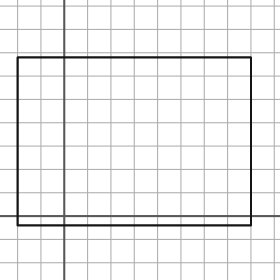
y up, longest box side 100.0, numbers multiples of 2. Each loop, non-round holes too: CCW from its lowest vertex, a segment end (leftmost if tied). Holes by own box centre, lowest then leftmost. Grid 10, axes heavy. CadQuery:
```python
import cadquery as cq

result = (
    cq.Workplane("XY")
    .moveTo(-20.0, -4.0)
    .lineTo(80.0, -4.0)
    .lineTo(80.0, 68.0)
    .lineTo(-20.0, 68.0)
    .close()
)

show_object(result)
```